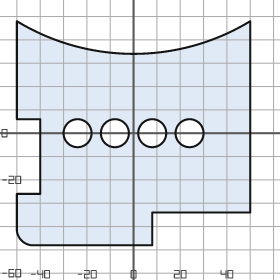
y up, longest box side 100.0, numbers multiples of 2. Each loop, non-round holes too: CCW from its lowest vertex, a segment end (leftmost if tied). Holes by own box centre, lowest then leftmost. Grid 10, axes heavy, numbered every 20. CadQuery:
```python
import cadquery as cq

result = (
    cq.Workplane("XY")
    .moveTo(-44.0, -48.0)
    .lineTo(8.0, -48.0)
    .lineTo(8.0, -34.0)
    .lineTo(50.0, -34.0)
    .lineTo(50.0, 48.0)
    .threePointArc((0.0, 34.0), (-50.0, 48.0))
    .lineTo(-50.0, 6.0)
    .lineTo(-40.0, 6.0)
    .lineTo(-40.0, -26.0)
    .lineTo(-50.0, -26.0)
    .lineTo(-50.0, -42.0)
    .threePointArc((-48.0, -46.0), (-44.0, -48.0))
    .close()
    .moveTo(-24.0, 0.0)
    .circle(6.0)
    .moveTo(-8.0, 0.0)
    .circle(6.0)
    .moveTo(8.0, 0.0)
    .circle(6.0)
    .moveTo(24.0, 0.0)
    .circle(6.0)
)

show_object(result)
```